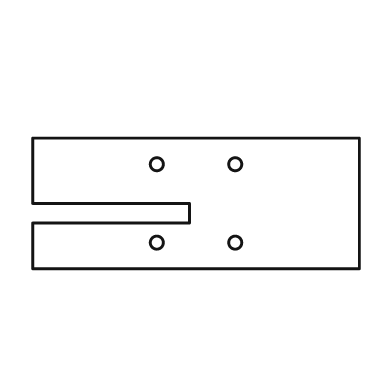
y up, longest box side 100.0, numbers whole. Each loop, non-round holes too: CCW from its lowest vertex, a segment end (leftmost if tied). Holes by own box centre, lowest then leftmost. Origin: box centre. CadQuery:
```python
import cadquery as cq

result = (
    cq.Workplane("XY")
    .moveTo(-50.0, -20.0)
    .lineTo(50.0, -20.0)
    .lineTo(50.0, 20.0)
    .lineTo(-50.0, 20.0)
    .lineTo(-50.0, 0.0)
    .lineTo(-2.0, 0.0)
    .lineTo(-2.0, -6.0)
    .lineTo(-50.0, -6.0)
    .close()
    .moveTo(-12.0, -12.0)
    .circle(2.0)
    .moveTo(12.0, -12.0)
    .circle(2.0)
    .moveTo(-12.0, 12.0)
    .circle(2.0)
    .moveTo(12.0, 12.0)
    .circle(2.0)
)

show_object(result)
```